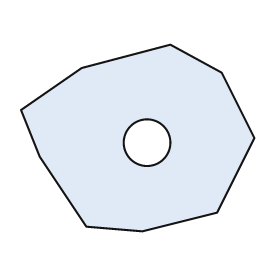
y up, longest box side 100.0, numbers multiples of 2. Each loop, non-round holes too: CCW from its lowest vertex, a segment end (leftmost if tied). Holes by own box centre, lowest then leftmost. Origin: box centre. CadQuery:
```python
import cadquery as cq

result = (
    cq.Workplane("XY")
    .moveTo(2.0, -40.0)
    .lineTo(34.0, -32.0)
    .lineTo(50.0, 0.0)
    .lineTo(36.0, 28.0)
    .lineTo(14.0, 40.0)
    .lineTo(-24.0, 30.0)
    .lineTo(-50.0, 12.0)
    .lineTo(-42.0, -8.0)
    .lineTo(-22.0, -38.0)
    .close()
    .moveTo(4.0, -2.0)
    .circle(10.0)
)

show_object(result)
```